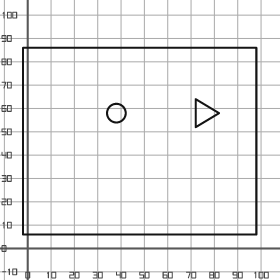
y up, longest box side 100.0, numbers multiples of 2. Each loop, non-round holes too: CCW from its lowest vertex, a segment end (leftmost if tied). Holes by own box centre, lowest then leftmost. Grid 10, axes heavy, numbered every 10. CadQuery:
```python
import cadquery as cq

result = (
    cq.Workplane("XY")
    .moveTo(-2.0, 6.0)
    .lineTo(98.0, 6.0)
    .lineTo(98.0, 86.0)
    .lineTo(-2.0, 86.0)
    .close()
    .moveTo(38.0, 58.0)
    .circle(4.0)
    .moveTo(72.0, 52.0)
    .lineTo(82.0, 58.0)
    .lineTo(72.0, 64.0)
    .close()
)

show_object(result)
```